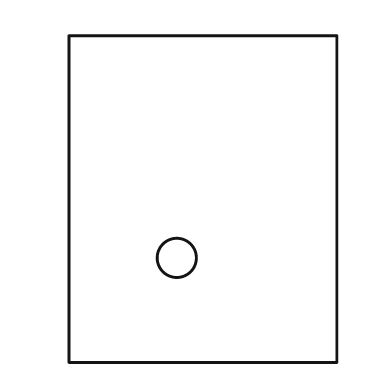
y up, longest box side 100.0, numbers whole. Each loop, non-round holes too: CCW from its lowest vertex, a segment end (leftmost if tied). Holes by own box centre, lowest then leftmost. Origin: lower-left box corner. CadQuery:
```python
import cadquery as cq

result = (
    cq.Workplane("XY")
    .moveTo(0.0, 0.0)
    .lineTo(82.0, 0.0)
    .lineTo(82.0, 100.0)
    .lineTo(0.0, 100.0)
    .close()
    .moveTo(33.0, 32.0)
    .circle(6.0)
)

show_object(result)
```